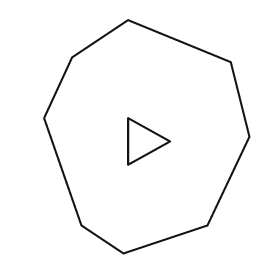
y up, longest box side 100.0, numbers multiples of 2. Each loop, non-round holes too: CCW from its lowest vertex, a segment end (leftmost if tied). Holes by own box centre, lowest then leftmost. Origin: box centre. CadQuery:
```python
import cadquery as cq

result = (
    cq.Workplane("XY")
    .moveTo(-10.0, -50.0)
    .lineTo(26.0, -38.0)
    .lineTo(44.0, 0.0)
    .lineTo(36.0, 32.0)
    .lineTo(-8.0, 50.0)
    .lineTo(-32.0, 34.0)
    .lineTo(-44.0, 8.0)
    .lineTo(-28.0, -38.0)
    .close()
    .moveTo(-8.0, -12.0)
    .lineTo(10.0, -2.0)
    .lineTo(-8.0, 8.0)
    .close()
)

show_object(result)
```